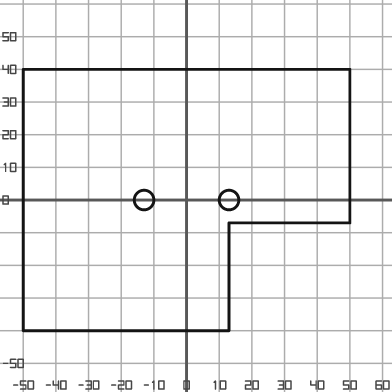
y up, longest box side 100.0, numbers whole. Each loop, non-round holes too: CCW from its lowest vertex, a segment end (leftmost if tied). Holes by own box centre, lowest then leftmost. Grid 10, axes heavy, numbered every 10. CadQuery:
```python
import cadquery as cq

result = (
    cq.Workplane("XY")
    .moveTo(-50.0, -40.0)
    .lineTo(13.0, -40.0)
    .lineTo(13.0, -7.0)
    .lineTo(50.0, -7.0)
    .lineTo(50.0, 40.0)
    .lineTo(-50.0, 40.0)
    .close()
    .moveTo(-13.0, 0.0)
    .circle(3.0)
    .moveTo(13.0, 0.0)
    .circle(3.0)
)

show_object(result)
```